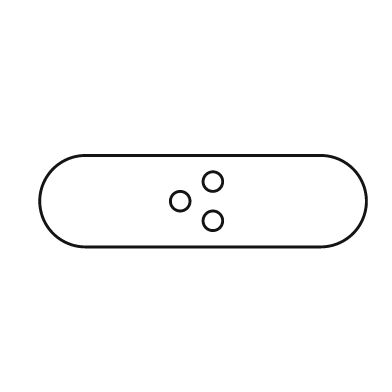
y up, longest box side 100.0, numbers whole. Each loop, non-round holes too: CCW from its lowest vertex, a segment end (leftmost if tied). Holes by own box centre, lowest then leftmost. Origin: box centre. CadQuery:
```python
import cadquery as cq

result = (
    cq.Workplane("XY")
    .moveTo(-36.0, -14.0)
    .lineTo(36.0, -14.0)
    .threePointArc((50.0, 0.0), (36.0, 14.0))
    .lineTo(-36.0, 14.0)
    .threePointArc((-50.0, 0.0), (-36.0, -14.0))
    .close()
    .moveTo(3.0, -6.0)
    .circle(3.0)
    .moveTo(-7.0, 0.0)
    .circle(3.0)
    .moveTo(3.0, 6.0)
    .circle(3.0)
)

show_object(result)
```